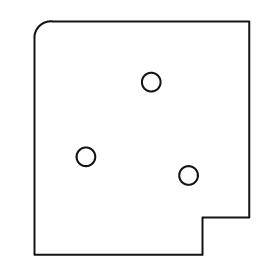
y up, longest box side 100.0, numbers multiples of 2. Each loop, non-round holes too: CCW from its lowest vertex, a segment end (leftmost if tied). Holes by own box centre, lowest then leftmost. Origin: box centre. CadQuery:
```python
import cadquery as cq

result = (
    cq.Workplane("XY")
    .moveTo(-46.0, -50.0)
    .lineTo(26.0, -50.0)
    .lineTo(26.0, -34.0)
    .lineTo(46.0, -34.0)
    .lineTo(46.0, 50.0)
    .lineTo(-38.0, 50.0)
    .threePointArc((-44.0, 48.0), (-46.0, 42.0))
    .close()
    .moveTo(20.0, -16.0)
    .circle(4.0)
    .moveTo(-24.0, -8.0)
    .circle(4.0)
    .moveTo(4.0, 24.0)
    .circle(4.0)
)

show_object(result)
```